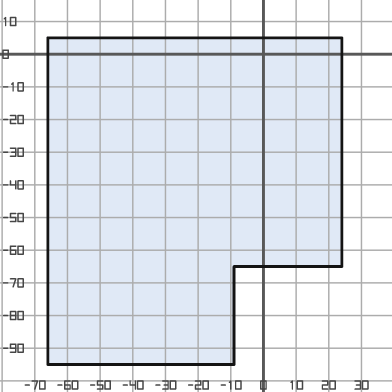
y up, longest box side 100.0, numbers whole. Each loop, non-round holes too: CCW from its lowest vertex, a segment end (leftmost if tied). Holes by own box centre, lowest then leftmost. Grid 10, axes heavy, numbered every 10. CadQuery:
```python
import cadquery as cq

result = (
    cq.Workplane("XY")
    .moveTo(-66.0, -95.0)
    .lineTo(-9.0, -95.0)
    .lineTo(-9.0, -65.0)
    .lineTo(24.0, -65.0)
    .lineTo(24.0, 5.0)
    .lineTo(-66.0, 5.0)
    .close()
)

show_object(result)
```